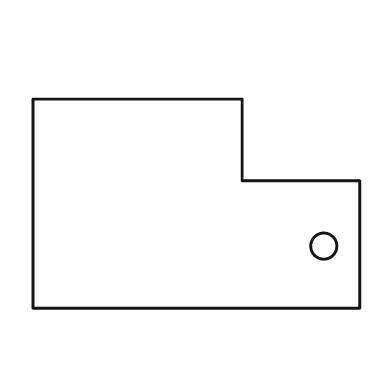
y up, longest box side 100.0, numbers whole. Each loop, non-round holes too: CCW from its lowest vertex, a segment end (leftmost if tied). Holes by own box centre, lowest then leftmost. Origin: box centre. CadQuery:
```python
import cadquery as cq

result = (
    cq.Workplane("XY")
    .moveTo(-50.0, -32.0)
    .lineTo(50.0, -32.0)
    .lineTo(50.0, 7.0)
    .lineTo(14.0, 7.0)
    .lineTo(14.0, 32.0)
    .lineTo(-50.0, 32.0)
    .close()
    .moveTo(39.0, -13.0)
    .circle(4.0)
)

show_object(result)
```